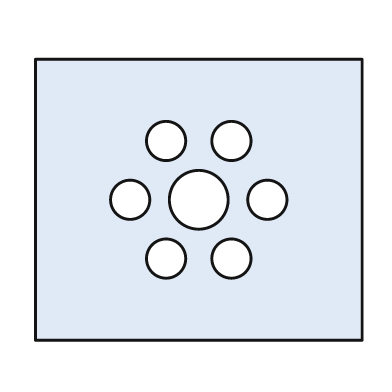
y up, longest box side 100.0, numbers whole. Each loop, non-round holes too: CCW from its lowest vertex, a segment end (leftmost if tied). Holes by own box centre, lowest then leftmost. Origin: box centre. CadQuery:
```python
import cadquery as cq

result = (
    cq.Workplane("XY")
    .moveTo(-50.0, -43.0)
    .lineTo(50.0, -43.0)
    .lineTo(50.0, 43.0)
    .lineTo(-50.0, 43.0)
    .close()
    .moveTo(-10.0, -18.0)
    .circle(6.0)
    .moveTo(10.0, -18.0)
    .circle(6.0)
    .moveTo(-21.0, 0.0)
    .circle(6.0)
    .moveTo(0.0, 0.0)
    .circle(9.0)
    .moveTo(21.0, 0.0)
    .circle(6.0)
    .moveTo(-10.0, 18.0)
    .circle(6.0)
    .moveTo(10.0, 18.0)
    .circle(6.0)
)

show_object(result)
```